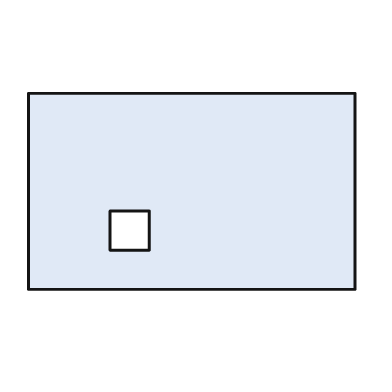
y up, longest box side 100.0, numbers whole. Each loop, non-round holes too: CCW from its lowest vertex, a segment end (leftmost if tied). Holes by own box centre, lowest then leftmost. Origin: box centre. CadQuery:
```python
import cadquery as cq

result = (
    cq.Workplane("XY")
    .moveTo(-50.0, -30.0)
    .lineTo(50.0, -30.0)
    .lineTo(50.0, 30.0)
    .lineTo(-50.0, 30.0)
    .close()
    .moveTo(-25.0, -18.0)
    .lineTo(-13.0, -18.0)
    .lineTo(-13.0, -6.0)
    .lineTo(-25.0, -6.0)
    .close()
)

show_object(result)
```